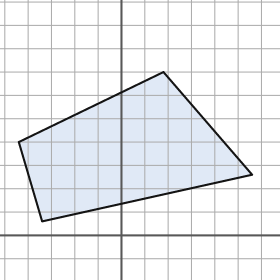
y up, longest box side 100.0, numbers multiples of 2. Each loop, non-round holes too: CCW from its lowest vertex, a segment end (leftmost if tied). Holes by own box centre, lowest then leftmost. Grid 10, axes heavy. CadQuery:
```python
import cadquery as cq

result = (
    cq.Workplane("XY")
    .moveTo(-34.0, 6.0)
    .lineTo(56.0, 26.0)
    .lineTo(18.0, 70.0)
    .lineTo(-44.0, 40.0)
    .close()
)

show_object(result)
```